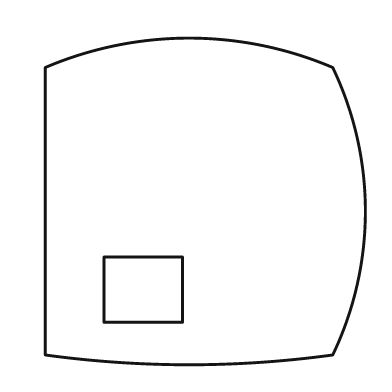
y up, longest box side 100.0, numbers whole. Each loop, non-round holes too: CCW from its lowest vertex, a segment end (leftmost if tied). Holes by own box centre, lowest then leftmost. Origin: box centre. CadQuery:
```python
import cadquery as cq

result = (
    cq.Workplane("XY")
    .moveTo(-49.0, -47.0)
    .threePointArc((-5.0, -50.0), (39.0, -47.0))
    .threePointArc((49.0, -3.0), (39.0, 41.0))
    .threePointArc((-5.0, 50.0), (-49.0, 41.0))
    .close()
    .moveTo(-31.0, -37.0)
    .lineTo(-7.0, -37.0)
    .lineTo(-7.0, -17.0)
    .lineTo(-31.0, -17.0)
    .close()
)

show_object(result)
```